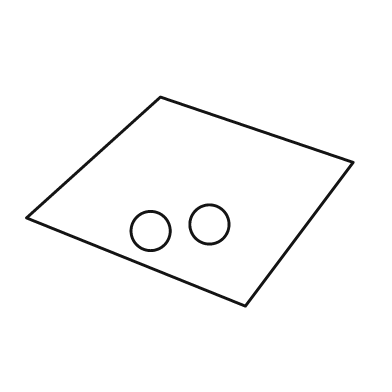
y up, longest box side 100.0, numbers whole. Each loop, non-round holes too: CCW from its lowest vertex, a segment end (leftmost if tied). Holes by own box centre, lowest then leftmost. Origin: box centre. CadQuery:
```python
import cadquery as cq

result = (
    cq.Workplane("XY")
    .moveTo(17.0, -32.0)
    .lineTo(50.0, 12.0)
    .lineTo(-9.0, 32.0)
    .lineTo(-50.0, -5.0)
    .close()
    .moveTo(-12.0, -9.0)
    .circle(6.0)
    .moveTo(6.0, -7.0)
    .circle(6.0)
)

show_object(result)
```